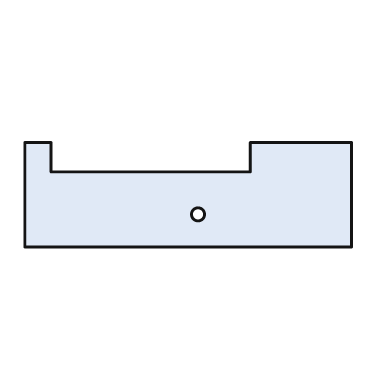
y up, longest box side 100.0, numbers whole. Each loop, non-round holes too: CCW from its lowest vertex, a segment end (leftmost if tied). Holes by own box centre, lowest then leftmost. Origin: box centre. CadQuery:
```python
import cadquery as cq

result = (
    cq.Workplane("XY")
    .moveTo(-50.0, -16.0)
    .lineTo(50.0, -16.0)
    .lineTo(50.0, 16.0)
    .lineTo(19.0, 16.0)
    .lineTo(19.0, 7.0)
    .lineTo(-42.0, 7.0)
    .lineTo(-42.0, 16.0)
    .lineTo(-50.0, 16.0)
    .close()
    .moveTo(3.0, -6.0)
    .circle(2.0)
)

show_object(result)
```